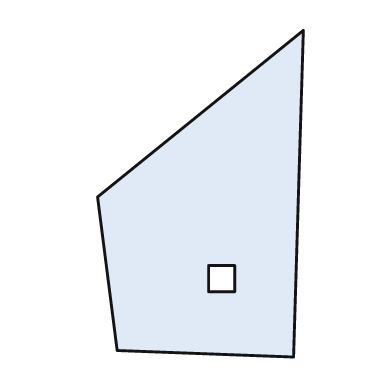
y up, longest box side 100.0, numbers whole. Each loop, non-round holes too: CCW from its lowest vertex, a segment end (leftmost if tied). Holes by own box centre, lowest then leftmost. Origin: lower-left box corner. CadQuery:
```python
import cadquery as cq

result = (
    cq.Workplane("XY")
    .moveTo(60.0, 0.0)
    .lineTo(63.0, 100.0)
    .lineTo(0.0, 49.0)
    .lineTo(6.0, 2.0)
    .close()
    .moveTo(34.0, 20.0)
    .lineTo(42.0, 20.0)
    .lineTo(42.0, 28.0)
    .lineTo(34.0, 28.0)
    .close()
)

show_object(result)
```